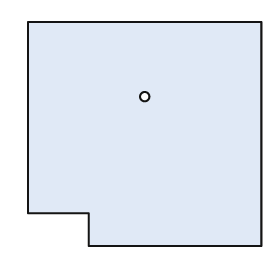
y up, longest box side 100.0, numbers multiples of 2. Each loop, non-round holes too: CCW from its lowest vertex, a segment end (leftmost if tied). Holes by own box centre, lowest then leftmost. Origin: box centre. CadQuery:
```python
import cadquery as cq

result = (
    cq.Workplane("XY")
    .moveTo(-24.0, -48.0)
    .lineTo(50.0, -48.0)
    .lineTo(50.0, 48.0)
    .lineTo(-50.0, 48.0)
    .lineTo(-50.0, -34.0)
    .lineTo(-24.0, -34.0)
    .close()
    .moveTo(0.0, 16.0)
    .circle(2.0)
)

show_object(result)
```